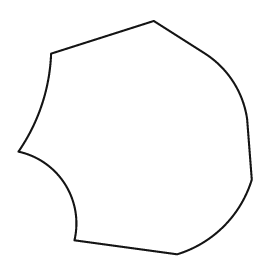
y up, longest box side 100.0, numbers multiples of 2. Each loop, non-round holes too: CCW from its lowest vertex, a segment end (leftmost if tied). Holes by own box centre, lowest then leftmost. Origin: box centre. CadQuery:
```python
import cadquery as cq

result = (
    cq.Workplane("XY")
    .moveTo(18.0, -50.0)
    .threePointArc((38.0, -38.0), (50.0, -18.0))
    .lineTo(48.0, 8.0)
    .threePointArc((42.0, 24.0), (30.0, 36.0))
    .lineTo(8.0, 50.0)
    .lineTo(-36.0, 36.0)
    .threePointArc((-40.0, 14.0), (-50.0, -6.0))
    .threePointArc((-30.0, -20.0), (-26.0, -44.0))
    .close()
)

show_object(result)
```